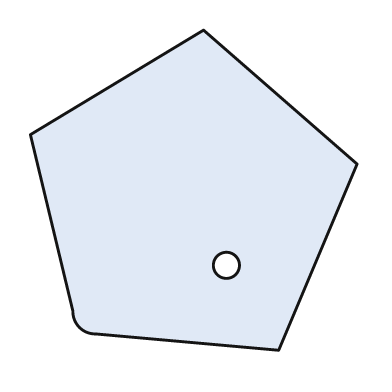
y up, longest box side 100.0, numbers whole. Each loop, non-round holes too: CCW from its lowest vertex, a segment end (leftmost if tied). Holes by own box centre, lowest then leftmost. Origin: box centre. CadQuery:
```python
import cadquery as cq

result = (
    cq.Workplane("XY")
    .moveTo(26.0, -49.0)
    .lineTo(50.0, 8.0)
    .lineTo(3.0, 49.0)
    .lineTo(-50.0, 17.0)
    .lineTo(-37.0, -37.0)
    .threePointArc((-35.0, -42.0), (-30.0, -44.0))
    .close()
    .moveTo(10.0, -23.0)
    .circle(4.0)
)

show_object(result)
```